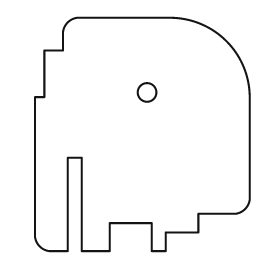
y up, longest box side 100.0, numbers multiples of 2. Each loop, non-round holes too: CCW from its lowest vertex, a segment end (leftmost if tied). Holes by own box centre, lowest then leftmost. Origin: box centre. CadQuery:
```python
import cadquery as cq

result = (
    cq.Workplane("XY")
    .moveTo(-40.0, -50.0)
    .lineTo(-32.0, -50.0)
    .lineTo(-32.0, -10.0)
    .lineTo(-26.0, -10.0)
    .lineTo(-26.0, -50.0)
    .lineTo(-14.0, -50.0)
    .lineTo(-14.0, -38.0)
    .lineTo(4.0, -38.0)
    .lineTo(4.0, -50.0)
    .lineTo(10.0, -50.0)
    .lineTo(10.0, -42.0)
    .lineTo(24.0, -42.0)
    .lineTo(24.0, -34.0)
    .lineTo(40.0, -34.0)
    .threePointArc((44.0, -32.0), (46.0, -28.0))
    .lineTo(46.0, 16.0)
    .threePointArc((36.0, 40.0), (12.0, 50.0))
    .lineTo(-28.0, 50.0)
    .threePointArc((-32.0, 48.0), (-34.0, 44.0))
    .lineTo(-34.0, 36.0)
    .lineTo(-42.0, 36.0)
    .lineTo(-42.0, 16.0)
    .lineTo(-46.0, 16.0)
    .lineTo(-46.0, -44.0)
    .threePointArc((-44.0, -48.0), (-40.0, -50.0))
    .close()
    .moveTo(2.0, 18.0)
    .circle(4.0)
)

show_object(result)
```